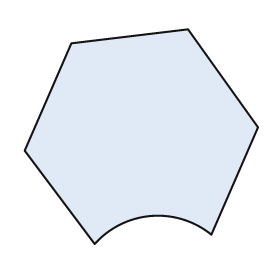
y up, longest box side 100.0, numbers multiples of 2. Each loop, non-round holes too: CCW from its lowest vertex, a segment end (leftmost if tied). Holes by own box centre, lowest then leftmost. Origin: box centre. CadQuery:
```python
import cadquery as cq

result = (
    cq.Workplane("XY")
    .moveTo(-20.0, -46.0)
    .threePointArc((4.0, -34.0), (30.0, -42.0))
    .lineTo(50.0, 4.0)
    .lineTo(20.0, 46.0)
    .lineTo(-30.0, 40.0)
    .lineTo(-50.0, -6.0)
    .close()
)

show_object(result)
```